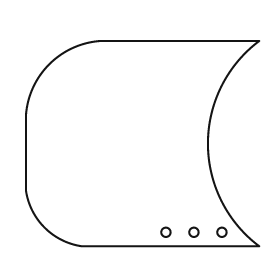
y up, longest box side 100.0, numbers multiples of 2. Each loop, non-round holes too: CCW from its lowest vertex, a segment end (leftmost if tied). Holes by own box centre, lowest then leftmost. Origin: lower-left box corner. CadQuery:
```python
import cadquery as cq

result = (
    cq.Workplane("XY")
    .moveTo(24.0, 0.0)
    .lineTo(100.0, 0.0)
    .threePointArc((78.0, 44.0), (100.0, 88.0))
    .lineTo(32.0, 88.0)
    .threePointArc((10.0, 78.0), (0.0, 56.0))
    .lineTo(0.0, 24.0)
    .threePointArc((8.0, 8.0), (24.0, 0.0))
    .close()
    .moveTo(60.0, 6.0)
    .circle(2.0)
    .moveTo(72.0, 6.0)
    .circle(2.0)
    .moveTo(84.0, 6.0)
    .circle(2.0)
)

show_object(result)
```